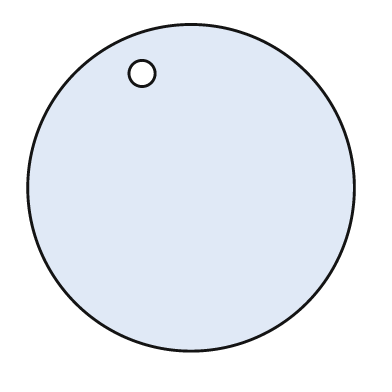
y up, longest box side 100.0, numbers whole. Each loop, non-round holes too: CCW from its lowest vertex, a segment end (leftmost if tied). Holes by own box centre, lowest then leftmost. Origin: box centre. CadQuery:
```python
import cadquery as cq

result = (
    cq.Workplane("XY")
    .moveTo(0.0, 0.0)
    .circle(50.0)
    .moveTo(-15.0, 35.0)
    .circle(4.0)
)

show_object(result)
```